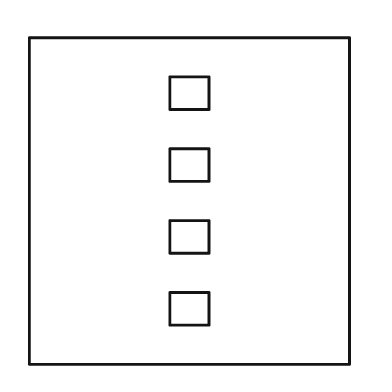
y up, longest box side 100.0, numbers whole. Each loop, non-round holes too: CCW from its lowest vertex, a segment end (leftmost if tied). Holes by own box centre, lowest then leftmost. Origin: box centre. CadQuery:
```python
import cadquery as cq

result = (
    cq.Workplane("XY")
    .moveTo(-49.0, -50.0)
    .lineTo(49.0, -50.0)
    .lineTo(49.0, 50.0)
    .lineTo(-49.0, 50.0)
    .close()
    .moveTo(-6.0, -38.0)
    .lineTo(6.0, -38.0)
    .lineTo(6.0, -28.0)
    .lineTo(-6.0, -28.0)
    .close()
    .moveTo(-6.0, -16.0)
    .lineTo(6.0, -16.0)
    .lineTo(6.0, -6.0)
    .lineTo(-6.0, -6.0)
    .close()
    .moveTo(-6.0, 6.0)
    .lineTo(6.0, 6.0)
    .lineTo(6.0, 16.0)
    .lineTo(-6.0, 16.0)
    .close()
    .moveTo(-6.0, 28.0)
    .lineTo(6.0, 28.0)
    .lineTo(6.0, 38.0)
    .lineTo(-6.0, 38.0)
    .close()
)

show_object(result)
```